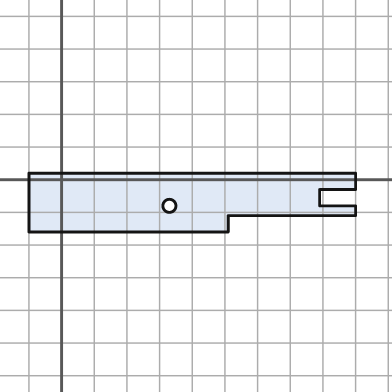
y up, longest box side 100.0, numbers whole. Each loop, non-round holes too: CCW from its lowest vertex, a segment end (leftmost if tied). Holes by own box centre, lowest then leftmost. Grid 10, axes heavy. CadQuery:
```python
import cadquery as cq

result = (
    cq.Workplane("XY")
    .moveTo(-10.0, -16.0)
    .lineTo(51.0, -16.0)
    .lineTo(51.0, -11.0)
    .lineTo(90.0, -11.0)
    .lineTo(90.0, -8.0)
    .lineTo(79.0, -8.0)
    .lineTo(79.0, -3.0)
    .lineTo(90.0, -3.0)
    .lineTo(90.0, 2.0)
    .lineTo(-10.0, 2.0)
    .close()
    .moveTo(33.0, -8.0)
    .circle(2.0)
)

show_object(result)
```